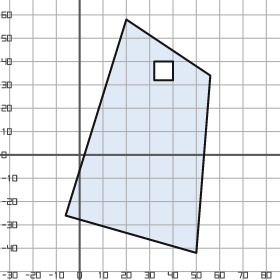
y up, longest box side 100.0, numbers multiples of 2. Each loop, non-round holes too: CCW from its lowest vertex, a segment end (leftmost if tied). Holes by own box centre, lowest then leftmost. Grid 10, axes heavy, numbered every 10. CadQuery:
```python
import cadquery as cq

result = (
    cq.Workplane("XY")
    .moveTo(50.0, -42.0)
    .lineTo(56.0, 34.0)
    .lineTo(20.0, 58.0)
    .lineTo(-6.0, -26.0)
    .close()
    .moveTo(32.0, 32.0)
    .lineTo(40.0, 32.0)
    .lineTo(40.0, 40.0)
    .lineTo(32.0, 40.0)
    .close()
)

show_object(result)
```